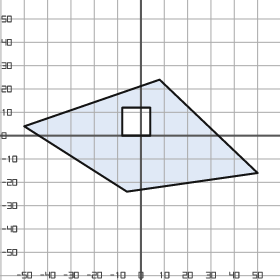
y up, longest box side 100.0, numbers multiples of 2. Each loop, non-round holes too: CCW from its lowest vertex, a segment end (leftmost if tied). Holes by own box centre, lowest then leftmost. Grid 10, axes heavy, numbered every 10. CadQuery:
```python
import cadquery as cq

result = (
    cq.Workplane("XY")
    .moveTo(-6.0, -24.0)
    .lineTo(50.0, -16.0)
    .lineTo(8.0, 24.0)
    .lineTo(-50.0, 4.0)
    .close()
    .moveTo(-8.0, 0.0)
    .lineTo(4.0, 0.0)
    .lineTo(4.0, 12.0)
    .lineTo(-8.0, 12.0)
    .close()
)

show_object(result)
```